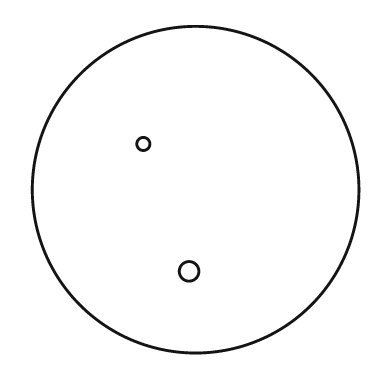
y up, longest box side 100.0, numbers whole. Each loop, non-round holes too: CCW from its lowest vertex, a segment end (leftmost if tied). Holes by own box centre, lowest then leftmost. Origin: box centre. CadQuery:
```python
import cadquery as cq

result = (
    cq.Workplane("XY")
    .moveTo(0.0, 0.0)
    .circle(50.0)
    .moveTo(-2.0, -25.0)
    .circle(3.0)
    .moveTo(-16.0, 14.0)
    .circle(2.0)
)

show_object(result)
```